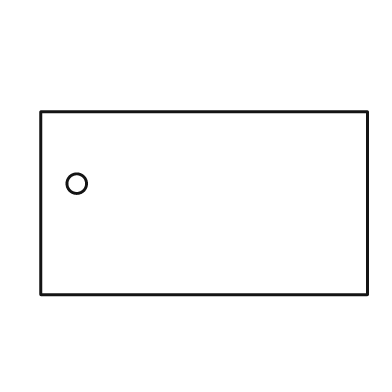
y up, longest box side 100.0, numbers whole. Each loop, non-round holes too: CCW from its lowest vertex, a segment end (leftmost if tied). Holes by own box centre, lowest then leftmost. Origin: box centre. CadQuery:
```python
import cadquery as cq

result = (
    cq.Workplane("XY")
    .moveTo(-50.0, -28.0)
    .lineTo(50.0, -28.0)
    .lineTo(50.0, 28.0)
    .lineTo(-50.0, 28.0)
    .close()
    .moveTo(-39.0, 6.0)
    .circle(3.0)
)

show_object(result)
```